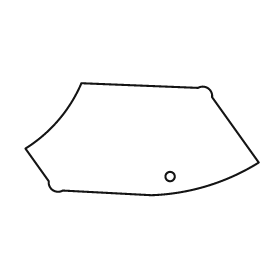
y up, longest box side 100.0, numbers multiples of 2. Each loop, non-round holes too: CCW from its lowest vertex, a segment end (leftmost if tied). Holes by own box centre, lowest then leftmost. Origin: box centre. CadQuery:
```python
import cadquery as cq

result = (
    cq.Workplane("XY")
    .moveTo(4.0, -24.0)
    .threePointArc((28.0, -20.0), (50.0, -10.0))
    .lineTo(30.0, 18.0)
    .threePointArc((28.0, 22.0), (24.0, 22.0))
    .lineTo(-26.0, 24.0)
    .threePointArc((-36.0, 8.0), (-50.0, -4.0))
    .lineTo(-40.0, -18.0)
    .threePointArc((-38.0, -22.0), (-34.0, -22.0))
    .close()
    .moveTo(12.0, -16.0)
    .circle(2.0)
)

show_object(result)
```